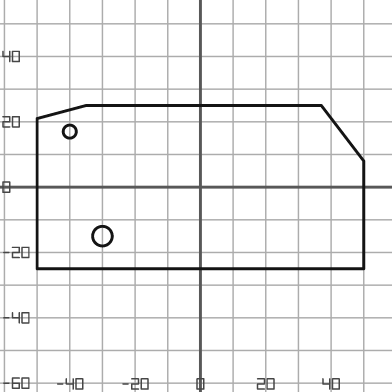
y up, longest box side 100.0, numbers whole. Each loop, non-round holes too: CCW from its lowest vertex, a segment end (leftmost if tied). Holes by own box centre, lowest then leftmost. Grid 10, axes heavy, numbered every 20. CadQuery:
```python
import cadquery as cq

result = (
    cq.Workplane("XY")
    .moveTo(-50.0, -25.0)
    .lineTo(50.0, -25.0)
    .lineTo(50.0, 8.0)
    .lineTo(37.0, 25.0)
    .lineTo(-35.0, 25.0)
    .lineTo(-50.0, 21.0)
    .close()
    .moveTo(-30.0, -15.0)
    .circle(3.0)
    .moveTo(-40.0, 17.0)
    .circle(2.0)
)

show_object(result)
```